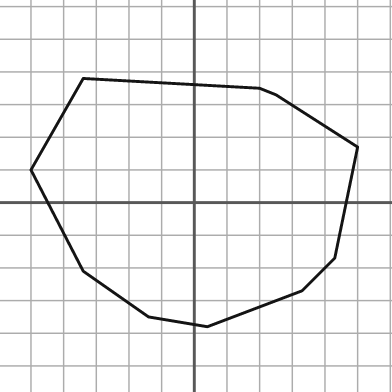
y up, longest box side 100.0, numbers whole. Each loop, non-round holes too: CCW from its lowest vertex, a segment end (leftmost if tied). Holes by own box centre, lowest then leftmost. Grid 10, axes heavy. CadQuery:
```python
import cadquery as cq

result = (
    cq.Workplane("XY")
    .moveTo(4.0, -38.0)
    .lineTo(33.0, -27.0)
    .lineTo(43.0, -17.0)
    .lineTo(50.0, 17.0)
    .lineTo(25.0, 33.0)
    .lineTo(20.0, 35.0)
    .lineTo(-34.0, 38.0)
    .lineTo(-50.0, 10.0)
    .lineTo(-34.0, -21.0)
    .lineTo(-14.0, -35.0)
    .close()
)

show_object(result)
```